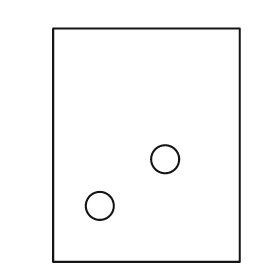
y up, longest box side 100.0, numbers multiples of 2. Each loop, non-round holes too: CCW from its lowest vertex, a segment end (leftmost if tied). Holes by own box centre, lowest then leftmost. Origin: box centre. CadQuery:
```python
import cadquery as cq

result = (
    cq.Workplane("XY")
    .moveTo(-40.0, -50.0)
    .lineTo(40.0, -50.0)
    .lineTo(40.0, 50.0)
    .lineTo(-40.0, 50.0)
    .close()
    .moveTo(-20.0, -26.0)
    .circle(6.0)
    .moveTo(8.0, -6.0)
    .circle(6.0)
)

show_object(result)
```